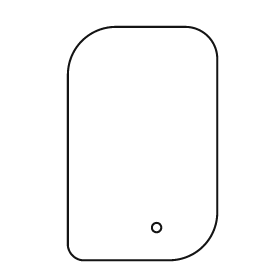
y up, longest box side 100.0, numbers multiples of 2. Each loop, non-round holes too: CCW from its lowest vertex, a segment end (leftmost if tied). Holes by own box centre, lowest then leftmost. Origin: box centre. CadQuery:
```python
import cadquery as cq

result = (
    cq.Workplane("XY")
    .moveTo(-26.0, -50.0)
    .lineTo(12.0, -50.0)
    .threePointArc((26.0, -44.0), (32.0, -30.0))
    .lineTo(32.0, 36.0)
    .threePointArc((28.0, 46.0), (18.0, 50.0))
    .lineTo(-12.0, 50.0)
    .threePointArc((-26.0, 44.0), (-32.0, 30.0))
    .lineTo(-32.0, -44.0)
    .threePointArc((-30.0, -48.0), (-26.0, -50.0))
    .close()
    .moveTo(6.0, -36.0)
    .circle(2.0)
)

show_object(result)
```